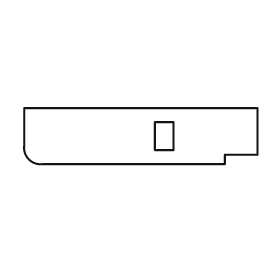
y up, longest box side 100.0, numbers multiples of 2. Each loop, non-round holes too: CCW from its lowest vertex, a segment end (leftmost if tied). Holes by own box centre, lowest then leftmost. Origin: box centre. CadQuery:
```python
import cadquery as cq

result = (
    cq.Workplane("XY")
    .moveTo(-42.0, -12.0)
    .lineTo(36.0, -12.0)
    .lineTo(36.0, -8.0)
    .lineTo(50.0, -8.0)
    .lineTo(50.0, 12.0)
    .lineTo(-50.0, 12.0)
    .lineTo(-50.0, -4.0)
    .threePointArc((-48.0, -10.0), (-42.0, -12.0))
    .close()
    .moveTo(6.0, -6.0)
    .lineTo(14.0, -6.0)
    .lineTo(14.0, 6.0)
    .lineTo(6.0, 6.0)
    .close()
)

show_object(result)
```